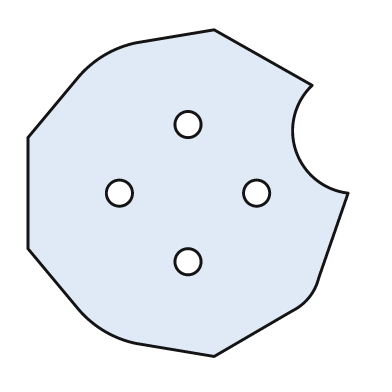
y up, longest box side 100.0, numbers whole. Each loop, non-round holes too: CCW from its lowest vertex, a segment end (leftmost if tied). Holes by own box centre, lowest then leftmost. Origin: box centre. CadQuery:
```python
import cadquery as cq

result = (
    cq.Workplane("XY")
    .moveTo(8.0, -50.0)
    .lineTo(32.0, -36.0)
    .threePointArc((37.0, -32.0), (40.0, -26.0))
    .lineTo(49.0, 0.0)
    .threePointArc((33.0, 13.0), (38.0, 33.0))
    .lineTo(8.0, 50.0)
    .lineTo(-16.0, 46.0)
    .threePointArc((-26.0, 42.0), (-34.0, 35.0))
    .lineTo(-49.0, 17.0)
    .lineTo(-49.0, -17.0)
    .lineTo(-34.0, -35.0)
    .threePointArc((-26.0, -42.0), (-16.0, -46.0))
    .close()
    .moveTo(0.0, -21.0)
    .circle(4.0)
    .moveTo(-21.0, 0.0)
    .circle(4.0)
    .moveTo(21.0, 0.0)
    .circle(4.0)
    .moveTo(0.0, 21.0)
    .circle(4.0)
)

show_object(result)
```